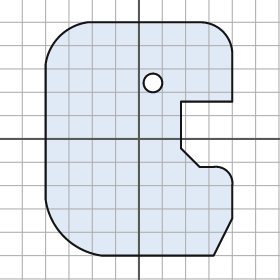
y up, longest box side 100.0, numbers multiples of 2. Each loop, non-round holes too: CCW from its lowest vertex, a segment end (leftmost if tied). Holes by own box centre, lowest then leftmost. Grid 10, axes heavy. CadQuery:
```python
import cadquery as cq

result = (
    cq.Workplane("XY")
    .moveTo(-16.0, -50.0)
    .lineTo(32.0, -50.0)
    .lineTo(40.0, -34.0)
    .lineTo(40.0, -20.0)
    .threePointArc((38.0, -14.0), (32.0, -12.0))
    .lineTo(26.0, -12.0)
    .lineTo(18.0, -4.0)
    .lineTo(18.0, 16.0)
    .lineTo(40.0, 16.0)
    .lineTo(40.0, 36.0)
    .threePointArc((36.0, 46.0), (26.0, 50.0))
    .lineTo(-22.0, 50.0)
    .threePointArc((-34.0, 44.0), (-40.0, 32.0))
    .lineTo(-40.0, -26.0)
    .threePointArc((-32.0, -42.0), (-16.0, -50.0))
    .close()
    .moveTo(6.0, 24.0)
    .circle(4.0)
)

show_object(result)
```